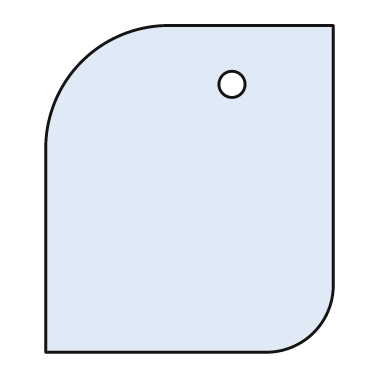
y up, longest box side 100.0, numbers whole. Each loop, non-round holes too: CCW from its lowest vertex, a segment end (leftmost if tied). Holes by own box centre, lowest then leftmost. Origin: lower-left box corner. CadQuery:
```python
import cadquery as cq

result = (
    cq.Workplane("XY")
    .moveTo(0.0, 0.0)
    .lineTo(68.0, 0.0)
    .threePointArc((82.0, 6.0), (88.0, 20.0))
    .lineTo(88.0, 100.0)
    .lineTo(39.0, 100.0)
    .threePointArc((11.0, 89.0), (0.0, 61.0))
    .close()
    .moveTo(57.0, 82.0)
    .circle(4.0)
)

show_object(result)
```